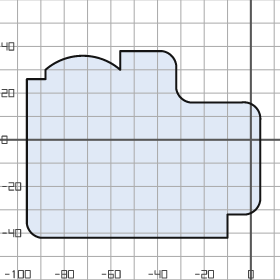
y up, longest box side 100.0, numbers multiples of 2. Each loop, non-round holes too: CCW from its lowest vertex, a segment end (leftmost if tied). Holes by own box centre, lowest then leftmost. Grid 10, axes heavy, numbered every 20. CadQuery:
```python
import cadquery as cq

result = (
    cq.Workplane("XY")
    .moveTo(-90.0, -42.0)
    .lineTo(-10.0, -42.0)
    .lineTo(-10.0, -32.0)
    .lineTo(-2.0, -32.0)
    .threePointArc((2.0, -30.0), (4.0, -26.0))
    .lineTo(4.0, 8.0)
    .threePointArc((2.0, 14.0), (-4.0, 16.0))
    .lineTo(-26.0, 16.0)
    .threePointArc((-30.0, 18.0), (-32.0, 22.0))
    .lineTo(-32.0, 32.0)
    .threePointArc((-34.0, 36.0), (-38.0, 38.0))
    .lineTo(-56.0, 38.0)
    .lineTo(-56.0, 30.0)
    .threePointArc((-72.0, 36.0), (-88.0, 30.0))
    .lineTo(-88.0, 26.0)
    .lineTo(-96.0, 26.0)
    .lineTo(-96.0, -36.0)
    .threePointArc((-94.0, -40.0), (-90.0, -42.0))
    .close()
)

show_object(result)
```